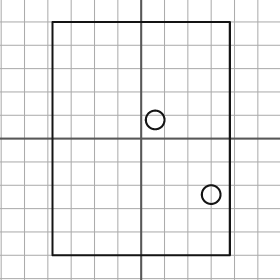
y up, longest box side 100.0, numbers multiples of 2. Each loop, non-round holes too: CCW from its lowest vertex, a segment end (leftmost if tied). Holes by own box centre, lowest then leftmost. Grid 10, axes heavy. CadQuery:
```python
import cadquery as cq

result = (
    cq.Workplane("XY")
    .moveTo(-38.0, -50.0)
    .lineTo(38.0, -50.0)
    .lineTo(38.0, 50.0)
    .lineTo(-38.0, 50.0)
    .close()
    .moveTo(30.0, -24.0)
    .circle(4.0)
    .moveTo(6.0, 8.0)
    .circle(4.0)
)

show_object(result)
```